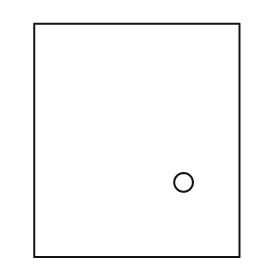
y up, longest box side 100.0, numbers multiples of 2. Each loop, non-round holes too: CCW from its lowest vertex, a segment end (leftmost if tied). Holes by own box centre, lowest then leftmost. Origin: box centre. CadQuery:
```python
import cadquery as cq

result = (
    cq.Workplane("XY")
    .moveTo(-44.0, -50.0)
    .lineTo(44.0, -50.0)
    .lineTo(44.0, 50.0)
    .lineTo(-44.0, 50.0)
    .close()
    .moveTo(20.0, -18.0)
    .circle(4.0)
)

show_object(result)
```